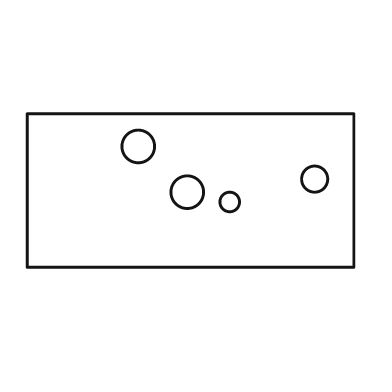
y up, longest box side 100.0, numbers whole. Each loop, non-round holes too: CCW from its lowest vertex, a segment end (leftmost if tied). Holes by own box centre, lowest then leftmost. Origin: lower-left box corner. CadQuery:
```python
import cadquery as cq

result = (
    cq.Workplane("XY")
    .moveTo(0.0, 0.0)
    .lineTo(100.0, 0.0)
    .lineTo(100.0, 47.0)
    .lineTo(0.0, 47.0)
    .close()
    .moveTo(62.0, 20.0)
    .circle(3.0)
    .moveTo(49.0, 23.0)
    .circle(5.0)
    .moveTo(88.0, 27.0)
    .circle(4.0)
    .moveTo(34.0, 37.0)
    .circle(5.0)
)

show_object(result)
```